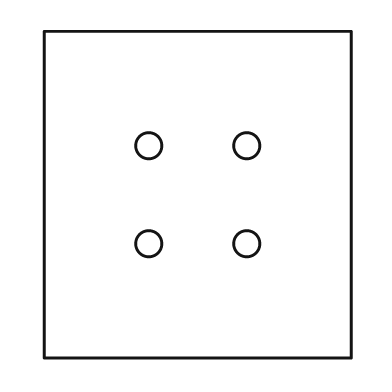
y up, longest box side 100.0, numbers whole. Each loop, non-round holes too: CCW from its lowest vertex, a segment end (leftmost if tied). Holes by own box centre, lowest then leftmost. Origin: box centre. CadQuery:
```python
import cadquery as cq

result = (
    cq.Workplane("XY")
    .moveTo(-47.0, -50.0)
    .lineTo(47.0, -50.0)
    .lineTo(47.0, 50.0)
    .lineTo(-47.0, 50.0)
    .close()
    .moveTo(-15.0, -15.0)
    .circle(4.0)
    .moveTo(15.0, -15.0)
    .circle(4.0)
    .moveTo(-15.0, 15.0)
    .circle(4.0)
    .moveTo(15.0, 15.0)
    .circle(4.0)
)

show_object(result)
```